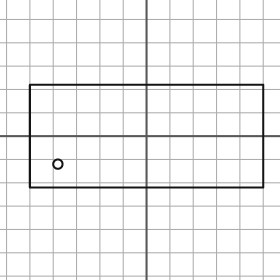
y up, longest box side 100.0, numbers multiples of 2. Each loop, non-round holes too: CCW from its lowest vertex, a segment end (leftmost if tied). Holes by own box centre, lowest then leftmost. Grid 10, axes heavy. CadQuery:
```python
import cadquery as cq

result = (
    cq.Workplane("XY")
    .moveTo(-50.0, -22.0)
    .lineTo(50.0, -22.0)
    .lineTo(50.0, 22.0)
    .lineTo(-50.0, 22.0)
    .close()
    .moveTo(-38.0, -12.0)
    .circle(2.0)
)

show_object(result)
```